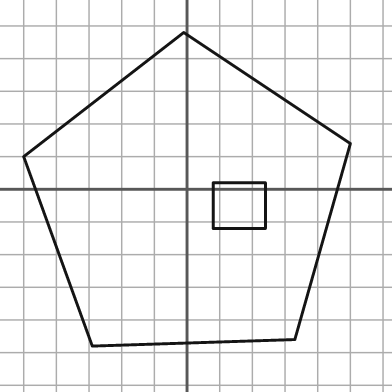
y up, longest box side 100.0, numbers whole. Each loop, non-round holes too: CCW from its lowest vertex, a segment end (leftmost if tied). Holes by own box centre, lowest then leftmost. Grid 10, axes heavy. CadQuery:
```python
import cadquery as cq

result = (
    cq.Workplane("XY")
    .moveTo(-29.0, -48.0)
    .lineTo(33.0, -46.0)
    .lineTo(50.0, 14.0)
    .lineTo(-1.0, 48.0)
    .lineTo(-50.0, 10.0)
    .close()
    .moveTo(8.0, -12.0)
    .lineTo(24.0, -12.0)
    .lineTo(24.0, 2.0)
    .lineTo(8.0, 2.0)
    .close()
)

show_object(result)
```